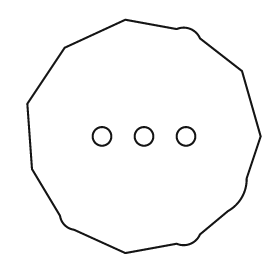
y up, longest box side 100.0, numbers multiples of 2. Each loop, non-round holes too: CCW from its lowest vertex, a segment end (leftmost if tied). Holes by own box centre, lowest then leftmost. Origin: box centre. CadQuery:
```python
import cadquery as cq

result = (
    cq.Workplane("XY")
    .moveTo(-8.0, -50.0)
    .lineTo(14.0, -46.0)
    .threePointArc((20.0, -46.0), (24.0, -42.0))
    .lineTo(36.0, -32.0)
    .threePointArc((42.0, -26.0), (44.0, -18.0))
    .lineTo(50.0, 0.0)
    .lineTo(42.0, 28.0)
    .lineTo(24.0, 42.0)
    .threePointArc((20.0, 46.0), (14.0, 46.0))
    .lineTo(-8.0, 50.0)
    .lineTo(-34.0, 38.0)
    .lineTo(-50.0, 14.0)
    .lineTo(-48.0, -14.0)
    .lineTo(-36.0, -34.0)
    .threePointArc((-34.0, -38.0), (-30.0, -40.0))
    .close()
    .moveTo(-18.0, 0.0)
    .circle(4.0)
    .moveTo(0.0, 0.0)
    .circle(4.0)
    .moveTo(18.0, 0.0)
    .circle(4.0)
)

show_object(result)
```